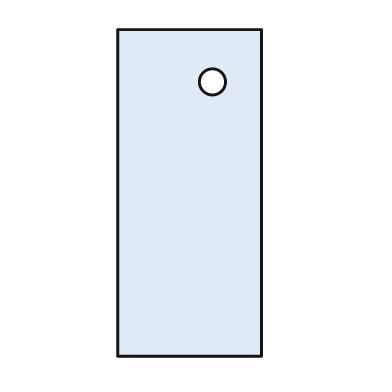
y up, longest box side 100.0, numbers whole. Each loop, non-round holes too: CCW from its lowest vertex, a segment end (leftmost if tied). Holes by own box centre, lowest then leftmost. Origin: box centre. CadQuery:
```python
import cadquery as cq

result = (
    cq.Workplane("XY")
    .moveTo(-22.0, -50.0)
    .lineTo(22.0, -50.0)
    .lineTo(22.0, 50.0)
    .lineTo(-22.0, 50.0)
    .close()
    .moveTo(7.0, 34.0)
    .circle(4.0)
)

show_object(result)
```